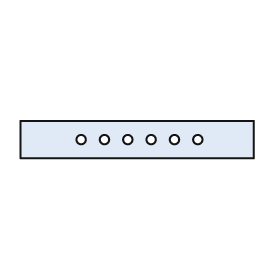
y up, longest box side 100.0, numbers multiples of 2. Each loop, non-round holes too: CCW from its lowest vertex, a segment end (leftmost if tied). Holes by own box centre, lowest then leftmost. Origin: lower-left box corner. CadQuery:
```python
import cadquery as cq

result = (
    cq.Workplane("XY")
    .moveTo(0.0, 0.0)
    .lineTo(100.0, 0.0)
    .lineTo(100.0, 16.0)
    .lineTo(0.0, 16.0)
    .close()
    .moveTo(26.0, 8.0)
    .circle(2.0)
    .moveTo(36.0, 8.0)
    .circle(2.0)
    .moveTo(46.0, 8.0)
    .circle(2.0)
    .moveTo(56.0, 8.0)
    .circle(2.0)
    .moveTo(66.0, 8.0)
    .circle(2.0)
    .moveTo(76.0, 8.0)
    .circle(2.0)
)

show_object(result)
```